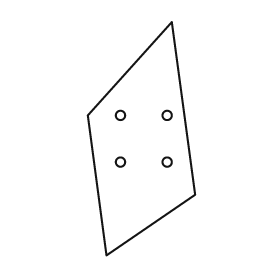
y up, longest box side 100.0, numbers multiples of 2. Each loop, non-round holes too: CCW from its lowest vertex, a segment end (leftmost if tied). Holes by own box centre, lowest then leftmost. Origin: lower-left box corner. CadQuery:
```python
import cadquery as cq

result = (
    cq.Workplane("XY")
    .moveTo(8.0, 0.0)
    .lineTo(46.0, 26.0)
    .lineTo(36.0, 100.0)
    .lineTo(0.0, 60.0)
    .close()
    .moveTo(14.0, 40.0)
    .circle(2.0)
    .moveTo(34.0, 40.0)
    .circle(2.0)
    .moveTo(14.0, 60.0)
    .circle(2.0)
    .moveTo(34.0, 60.0)
    .circle(2.0)
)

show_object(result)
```